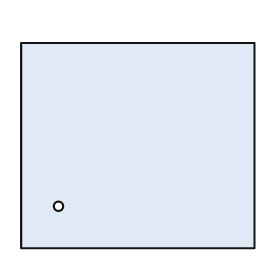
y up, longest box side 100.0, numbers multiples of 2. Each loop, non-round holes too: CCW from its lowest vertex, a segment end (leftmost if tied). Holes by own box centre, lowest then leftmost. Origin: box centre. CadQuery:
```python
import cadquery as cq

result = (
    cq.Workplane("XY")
    .moveTo(-50.0, -44.0)
    .lineTo(50.0, -44.0)
    .lineTo(50.0, 44.0)
    .lineTo(-50.0, 44.0)
    .close()
    .moveTo(-34.0, -26.0)
    .circle(2.0)
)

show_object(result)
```